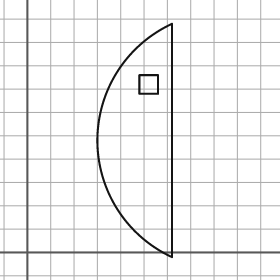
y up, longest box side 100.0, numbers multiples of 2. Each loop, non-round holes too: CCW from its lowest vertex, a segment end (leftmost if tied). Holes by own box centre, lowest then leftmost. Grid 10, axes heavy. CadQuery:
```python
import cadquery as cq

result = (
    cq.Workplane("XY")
    .moveTo(62.0, -2.0)
    .lineTo(62.0, 98.0)
    .threePointArc((30.0, 48.0), (62.0, -2.0))
    .close()
    .moveTo(48.0, 68.0)
    .lineTo(56.0, 68.0)
    .lineTo(56.0, 76.0)
    .lineTo(48.0, 76.0)
    .close()
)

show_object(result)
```